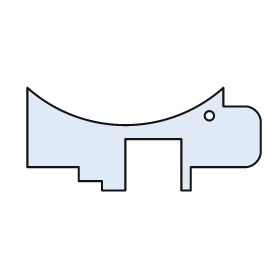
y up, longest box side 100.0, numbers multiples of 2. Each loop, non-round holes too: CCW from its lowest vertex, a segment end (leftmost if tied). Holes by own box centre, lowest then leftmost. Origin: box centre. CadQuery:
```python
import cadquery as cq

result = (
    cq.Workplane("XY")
    .moveTo(-18.0, -22.0)
    .lineTo(-8.0, -22.0)
    .lineTo(-8.0, 0.0)
    .lineTo(16.0, 0.0)
    .lineTo(16.0, -22.0)
    .lineTo(20.0, -22.0)
    .lineTo(20.0, -12.0)
    .lineTo(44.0, -12.0)
    .threePointArc((48.0, -10.0), (50.0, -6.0))
    .lineTo(50.0, 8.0)
    .threePointArc((48.0, 12.0), (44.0, 14.0))
    .lineTo(34.0, 14.0)
    .lineTo(34.0, 22.0)
    .threePointArc((-8.0, 6.0), (-50.0, 22.0))
    .lineTo(-50.0, -12.0)
    .lineTo(-28.0, -12.0)
    .lineTo(-28.0, -18.0)
    .lineTo(-18.0, -18.0)
    .close()
    .moveTo(28.0, 10.0)
    .circle(2.0)
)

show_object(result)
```